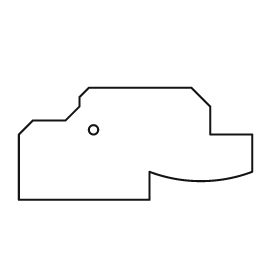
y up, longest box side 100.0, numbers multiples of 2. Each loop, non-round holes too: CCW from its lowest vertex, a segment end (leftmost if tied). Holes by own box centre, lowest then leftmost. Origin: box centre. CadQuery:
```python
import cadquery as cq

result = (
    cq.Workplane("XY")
    .moveTo(-50.0, -24.0)
    .lineTo(6.0, -24.0)
    .lineTo(6.0, -12.0)
    .threePointArc((28.0, -16.0), (50.0, -12.0))
    .lineTo(50.0, 4.0)
    .lineTo(32.0, 4.0)
    .lineTo(32.0, 16.0)
    .lineTo(24.0, 24.0)
    .lineTo(-20.0, 24.0)
    .lineTo(-24.0, 20.0)
    .lineTo(-24.0, 16.0)
    .lineTo(-30.0, 10.0)
    .lineTo(-44.0, 10.0)
    .lineTo(-50.0, 4.0)
    .close()
    .moveTo(-18.0, 6.0)
    .circle(2.0)
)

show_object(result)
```